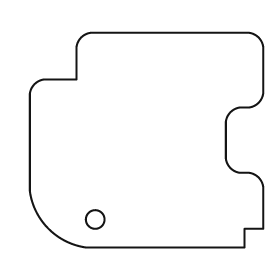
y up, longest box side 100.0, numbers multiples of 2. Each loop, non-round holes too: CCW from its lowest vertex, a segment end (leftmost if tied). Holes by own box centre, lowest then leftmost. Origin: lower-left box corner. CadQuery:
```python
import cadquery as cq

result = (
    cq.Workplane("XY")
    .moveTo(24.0, 0.0)
    .lineTo(92.0, 0.0)
    .lineTo(92.0, 8.0)
    .lineTo(100.0, 8.0)
    .lineTo(100.0, 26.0)
    .threePointArc((98.0, 30.0), (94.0, 32.0))
    .lineTo(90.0, 32.0)
    .threePointArc((86.0, 34.0), (84.0, 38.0))
    .lineTo(84.0, 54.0)
    .threePointArc((86.0, 58.0), (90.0, 60.0))
    .lineTo(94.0, 60.0)
    .threePointArc((98.0, 62.0), (100.0, 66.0))
    .lineTo(100.0, 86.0)
    .threePointArc((98.0, 90.0), (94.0, 92.0))
    .lineTo(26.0, 92.0)
    .threePointArc((22.0, 90.0), (20.0, 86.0))
    .lineTo(20.0, 72.0)
    .lineTo(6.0, 72.0)
    .threePointArc((2.0, 70.0), (0.0, 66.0))
    .lineTo(0.0, 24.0)
    .threePointArc((8.0, 8.0), (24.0, 0.0))
    .close()
    .moveTo(28.0, 12.0)
    .circle(4.0)
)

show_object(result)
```